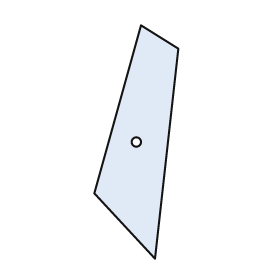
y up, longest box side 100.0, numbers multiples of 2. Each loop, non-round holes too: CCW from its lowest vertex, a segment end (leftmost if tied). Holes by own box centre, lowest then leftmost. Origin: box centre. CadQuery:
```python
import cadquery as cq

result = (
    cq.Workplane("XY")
    .moveTo(8.0, -50.0)
    .lineTo(18.0, 40.0)
    .lineTo(2.0, 50.0)
    .lineTo(-18.0, -22.0)
    .close()
    .moveTo(0.0, 0.0)
    .circle(2.0)
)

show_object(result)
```